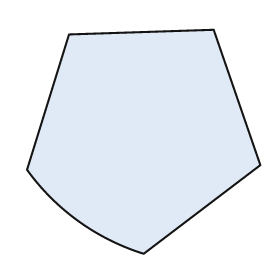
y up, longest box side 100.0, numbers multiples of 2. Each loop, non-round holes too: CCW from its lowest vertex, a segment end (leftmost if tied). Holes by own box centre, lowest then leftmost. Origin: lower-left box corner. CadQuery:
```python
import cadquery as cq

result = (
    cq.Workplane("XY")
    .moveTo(50.0, 0.0)
    .lineTo(100.0, 38.0)
    .lineTo(80.0, 96.0)
    .lineTo(18.0, 94.0)
    .lineTo(0.0, 36.0)
    .threePointArc((22.0, 14.0), (50.0, 0.0))
    .close()
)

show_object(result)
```